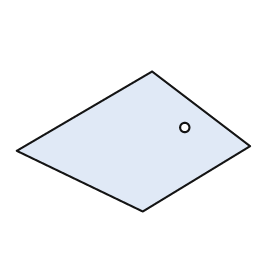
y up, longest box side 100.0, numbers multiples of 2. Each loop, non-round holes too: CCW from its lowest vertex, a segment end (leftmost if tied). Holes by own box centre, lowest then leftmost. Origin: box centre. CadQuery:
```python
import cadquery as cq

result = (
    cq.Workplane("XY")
    .moveTo(4.0, -30.0)
    .lineTo(50.0, -2.0)
    .lineTo(8.0, 30.0)
    .lineTo(-50.0, -4.0)
    .close()
    .moveTo(22.0, 6.0)
    .circle(2.0)
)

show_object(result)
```